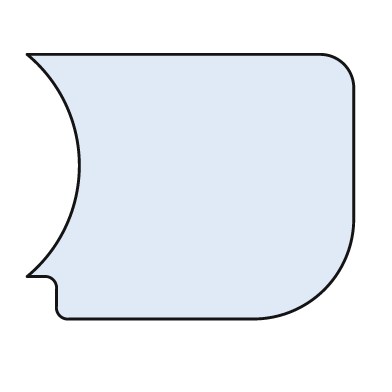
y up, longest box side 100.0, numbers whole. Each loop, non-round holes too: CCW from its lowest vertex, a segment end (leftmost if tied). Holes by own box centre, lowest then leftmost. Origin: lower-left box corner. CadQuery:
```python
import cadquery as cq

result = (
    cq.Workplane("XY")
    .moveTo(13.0, 0.0)
    .lineTo(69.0, 0.0)
    .threePointArc((91.0, 9.0), (100.0, 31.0))
    .lineTo(100.0, 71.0)
    .threePointArc((97.0, 78.0), (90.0, 81.0))
    .lineTo(0.0, 81.0)
    .threePointArc((16.0, 47.0), (0.0, 13.0))
    .lineTo(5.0, 13.0)
    .threePointArc((8.0, 12.0), (9.0, 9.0))
    .lineTo(9.0, 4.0)
    .threePointArc((10.0, 1.0), (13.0, 0.0))
    .close()
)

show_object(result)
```